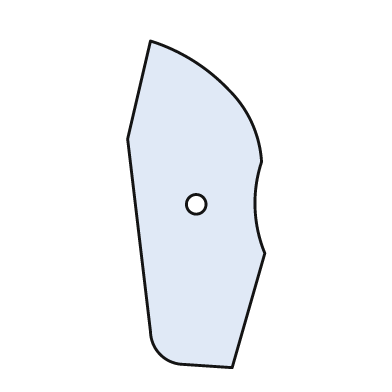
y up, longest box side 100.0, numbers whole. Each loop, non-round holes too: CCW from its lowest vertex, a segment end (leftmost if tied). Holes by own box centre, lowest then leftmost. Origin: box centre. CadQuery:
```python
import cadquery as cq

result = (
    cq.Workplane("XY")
    .moveTo(11.0, -50.0)
    .lineTo(21.0, -15.0)
    .threePointArc((18.0, -1.0), (20.0, 13.0))
    .threePointArc((17.0, 25.0), (10.0, 35.0))
    .threePointArc((-1.0, 44.0), (-14.0, 50.0))
    .lineTo(-21.0, 20.0)
    .lineTo(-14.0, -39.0)
    .threePointArc((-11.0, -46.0), (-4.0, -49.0))
    .close()
    .moveTo(0.0, 0.0)
    .circle(3.0)
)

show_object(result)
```